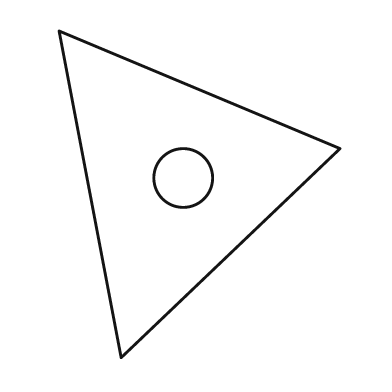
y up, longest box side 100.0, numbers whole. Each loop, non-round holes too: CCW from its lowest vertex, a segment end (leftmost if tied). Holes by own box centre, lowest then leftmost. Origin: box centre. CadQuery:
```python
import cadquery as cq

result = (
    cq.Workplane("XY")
    .moveTo(-24.0, -50.0)
    .lineTo(43.0, 14.0)
    .lineTo(-43.0, 50.0)
    .close()
    .moveTo(-5.0, 5.0)
    .circle(9.0)
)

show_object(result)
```